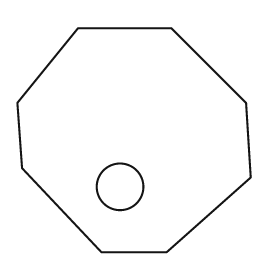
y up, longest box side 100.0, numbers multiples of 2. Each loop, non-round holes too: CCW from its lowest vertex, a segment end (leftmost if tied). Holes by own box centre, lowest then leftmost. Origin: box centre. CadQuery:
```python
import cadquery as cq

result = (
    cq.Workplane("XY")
    .moveTo(-14.0, -48.0)
    .lineTo(14.0, -48.0)
    .lineTo(50.0, -16.0)
    .lineTo(48.0, 16.0)
    .lineTo(16.0, 48.0)
    .lineTo(-24.0, 48.0)
    .lineTo(-50.0, 16.0)
    .lineTo(-48.0, -12.0)
    .close()
    .moveTo(-6.0, -20.0)
    .circle(10.0)
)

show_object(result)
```